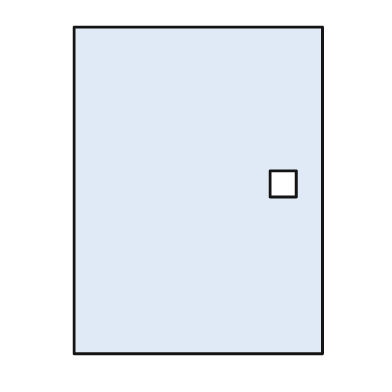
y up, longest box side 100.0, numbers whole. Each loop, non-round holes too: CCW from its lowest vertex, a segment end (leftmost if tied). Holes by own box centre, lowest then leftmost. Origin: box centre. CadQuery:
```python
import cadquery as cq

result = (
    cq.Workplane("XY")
    .moveTo(-38.0, -50.0)
    .lineTo(38.0, -50.0)
    .lineTo(38.0, 50.0)
    .lineTo(-38.0, 50.0)
    .close()
    .moveTo(22.0, -2.0)
    .lineTo(30.0, -2.0)
    .lineTo(30.0, 6.0)
    .lineTo(22.0, 6.0)
    .close()
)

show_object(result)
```